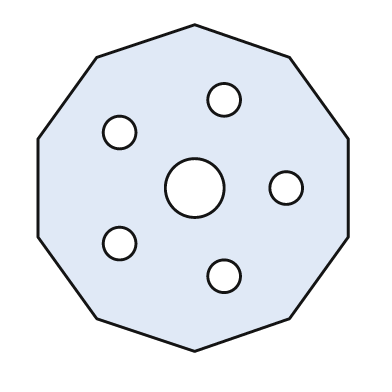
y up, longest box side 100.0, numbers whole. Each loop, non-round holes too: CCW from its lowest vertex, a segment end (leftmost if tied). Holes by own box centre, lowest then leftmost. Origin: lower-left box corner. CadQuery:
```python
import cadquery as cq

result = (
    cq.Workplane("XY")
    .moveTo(48.0, 0.0)
    .lineTo(77.0, 10.0)
    .lineTo(95.0, 35.0)
    .lineTo(95.0, 65.0)
    .lineTo(77.0, 90.0)
    .lineTo(48.0, 100.0)
    .lineTo(18.0, 90.0)
    .lineTo(0.0, 65.0)
    .lineTo(0.0, 35.0)
    .lineTo(18.0, 10.0)
    .close()
    .moveTo(57.0, 23.0)
    .circle(5.0)
    .moveTo(25.0, 33.0)
    .circle(5.0)
    .moveTo(48.0, 50.0)
    .circle(9.0)
    .moveTo(76.0, 50.0)
    .circle(5.0)
    .moveTo(25.0, 67.0)
    .circle(5.0)
    .moveTo(57.0, 77.0)
    .circle(5.0)
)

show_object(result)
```